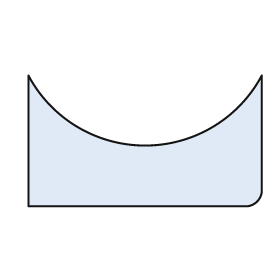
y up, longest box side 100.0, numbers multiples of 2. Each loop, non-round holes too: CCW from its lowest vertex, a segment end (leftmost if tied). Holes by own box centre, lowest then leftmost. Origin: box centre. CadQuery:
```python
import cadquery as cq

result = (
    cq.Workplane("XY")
    .moveTo(-50.0, -28.0)
    .lineTo(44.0, -28.0)
    .threePointArc((48.0, -26.0), (50.0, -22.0))
    .lineTo(50.0, 28.0)
    .threePointArc((0.0, -2.0), (-50.0, 28.0))
    .close()
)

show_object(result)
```